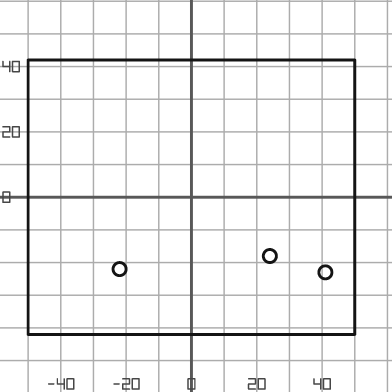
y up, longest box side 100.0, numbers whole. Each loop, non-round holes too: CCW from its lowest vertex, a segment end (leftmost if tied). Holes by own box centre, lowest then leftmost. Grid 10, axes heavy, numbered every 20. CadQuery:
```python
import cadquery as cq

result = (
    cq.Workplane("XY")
    .moveTo(-50.0, -42.0)
    .lineTo(50.0, -42.0)
    .lineTo(50.0, 42.0)
    .lineTo(-50.0, 42.0)
    .close()
    .moveTo(41.0, -23.0)
    .circle(2.0)
    .moveTo(-22.0, -22.0)
    .circle(2.0)
    .moveTo(24.0, -18.0)
    .circle(2.0)
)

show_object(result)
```